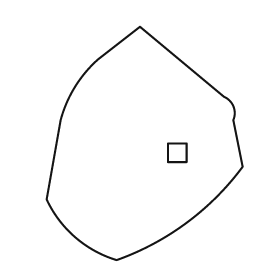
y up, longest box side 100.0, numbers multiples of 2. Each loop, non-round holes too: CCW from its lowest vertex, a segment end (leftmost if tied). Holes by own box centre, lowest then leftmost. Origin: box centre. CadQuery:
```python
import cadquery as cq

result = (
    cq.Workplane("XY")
    .moveTo(-12.0, -50.0)
    .threePointArc((18.0, -34.0), (42.0, -10.0))
    .lineTo(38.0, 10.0)
    .threePointArc((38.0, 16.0), (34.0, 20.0))
    .lineTo(-2.0, 50.0)
    .lineTo(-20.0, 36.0)
    .threePointArc((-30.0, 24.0), (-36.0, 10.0))
    .lineTo(-42.0, -24.0)
    .threePointArc((-30.0, -40.0), (-12.0, -50.0))
    .close()
    .moveTo(10.0, -8.0)
    .lineTo(18.0, -8.0)
    .lineTo(18.0, 0.0)
    .lineTo(10.0, 0.0)
    .close()
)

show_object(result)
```